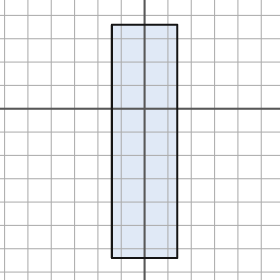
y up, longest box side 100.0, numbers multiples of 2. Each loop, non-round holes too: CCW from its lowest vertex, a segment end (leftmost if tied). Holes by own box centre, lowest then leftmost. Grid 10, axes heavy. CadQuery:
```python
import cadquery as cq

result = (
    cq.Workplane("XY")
    .moveTo(-14.0, -64.0)
    .lineTo(14.0, -64.0)
    .lineTo(14.0, 36.0)
    .lineTo(-14.0, 36.0)
    .close()
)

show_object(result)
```